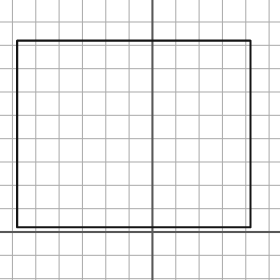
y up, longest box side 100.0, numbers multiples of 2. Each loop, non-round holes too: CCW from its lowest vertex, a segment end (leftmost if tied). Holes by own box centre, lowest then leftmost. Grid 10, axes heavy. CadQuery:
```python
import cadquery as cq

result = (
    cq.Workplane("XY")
    .moveTo(-58.0, 2.0)
    .lineTo(42.0, 2.0)
    .lineTo(42.0, 82.0)
    .lineTo(-58.0, 82.0)
    .close()
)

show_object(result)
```